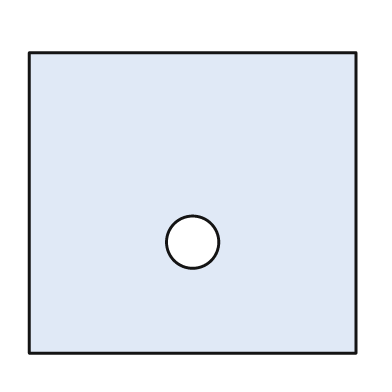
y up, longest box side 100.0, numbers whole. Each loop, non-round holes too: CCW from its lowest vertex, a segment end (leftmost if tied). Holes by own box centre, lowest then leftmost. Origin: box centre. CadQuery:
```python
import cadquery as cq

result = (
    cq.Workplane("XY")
    .moveTo(-50.0, -46.0)
    .lineTo(50.0, -46.0)
    .lineTo(50.0, 46.0)
    .lineTo(-50.0, 46.0)
    .close()
    .moveTo(0.0, -12.0)
    .circle(8.0)
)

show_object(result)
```